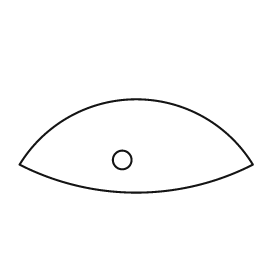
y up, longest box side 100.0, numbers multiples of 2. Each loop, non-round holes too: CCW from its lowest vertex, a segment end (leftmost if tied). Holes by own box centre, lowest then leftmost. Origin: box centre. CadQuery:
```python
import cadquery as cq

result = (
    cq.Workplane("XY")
    .moveTo(-50.0, -8.0)
    .threePointArc((0.0, -20.0), (50.0, -8.0))
    .threePointArc((0.0, 20.0), (-50.0, -8.0))
    .close()
    .moveTo(-6.0, -6.0)
    .circle(4.0)
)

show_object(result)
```